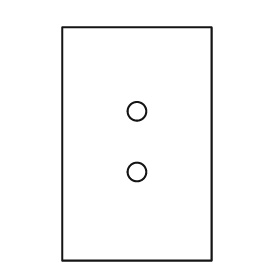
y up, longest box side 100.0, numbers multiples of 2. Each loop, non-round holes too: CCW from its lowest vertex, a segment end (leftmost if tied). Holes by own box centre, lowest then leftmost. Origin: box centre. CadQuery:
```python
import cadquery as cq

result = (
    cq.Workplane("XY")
    .moveTo(-32.0, -50.0)
    .lineTo(32.0, -50.0)
    .lineTo(32.0, 50.0)
    .lineTo(-32.0, 50.0)
    .close()
    .moveTo(0.0, -12.0)
    .circle(4.0)
    .moveTo(0.0, 14.0)
    .circle(4.0)
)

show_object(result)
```